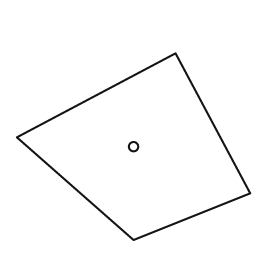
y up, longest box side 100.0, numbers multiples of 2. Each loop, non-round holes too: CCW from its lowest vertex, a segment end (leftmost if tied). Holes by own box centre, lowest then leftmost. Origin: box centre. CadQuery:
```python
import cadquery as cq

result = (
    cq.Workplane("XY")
    .moveTo(0.0, -40.0)
    .lineTo(50.0, -20.0)
    .lineTo(18.0, 40.0)
    .lineTo(-50.0, 4.0)
    .close()
    .moveTo(0.0, 0.0)
    .circle(2.0)
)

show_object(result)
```